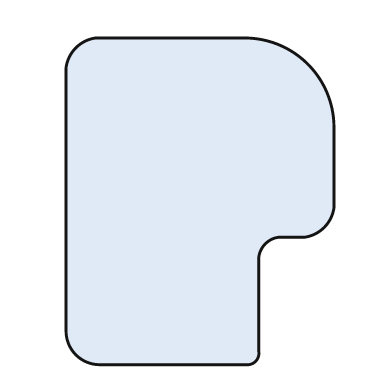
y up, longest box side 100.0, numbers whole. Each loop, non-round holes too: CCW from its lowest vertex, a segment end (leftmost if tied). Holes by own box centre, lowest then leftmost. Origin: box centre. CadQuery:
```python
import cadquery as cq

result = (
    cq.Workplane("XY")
    .moveTo(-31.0, -50.0)
    .lineTo(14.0, -50.0)
    .threePointArc((17.0, -49.0), (18.0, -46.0))
    .lineTo(18.0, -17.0)
    .threePointArc((20.0, -13.0), (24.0, -11.0))
    .lineTo(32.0, -11.0)
    .threePointArc((38.0, -8.0), (41.0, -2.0))
    .lineTo(41.0, 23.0)
    .threePointArc((33.0, 42.0), (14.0, 50.0))
    .lineTo(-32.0, 50.0)
    .threePointArc((-38.0, 47.0), (-41.0, 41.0))
    .lineTo(-41.0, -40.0)
    .threePointArc((-38.0, -47.0), (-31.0, -50.0))
    .close()
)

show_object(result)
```